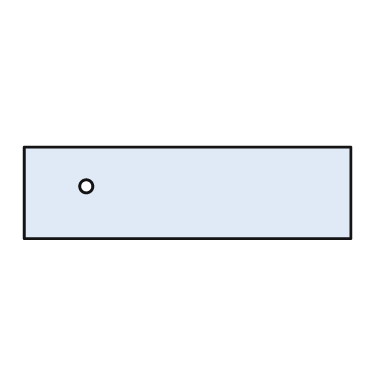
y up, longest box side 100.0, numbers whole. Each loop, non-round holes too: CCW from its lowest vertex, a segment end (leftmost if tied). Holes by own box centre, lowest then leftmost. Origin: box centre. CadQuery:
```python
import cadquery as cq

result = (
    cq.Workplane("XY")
    .moveTo(-50.0, -14.0)
    .lineTo(50.0, -14.0)
    .lineTo(50.0, 14.0)
    .lineTo(-50.0, 14.0)
    .close()
    .moveTo(-31.0, 2.0)
    .circle(2.0)
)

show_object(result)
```